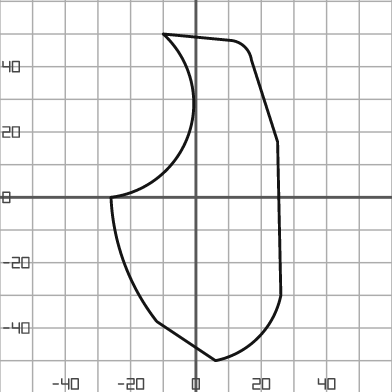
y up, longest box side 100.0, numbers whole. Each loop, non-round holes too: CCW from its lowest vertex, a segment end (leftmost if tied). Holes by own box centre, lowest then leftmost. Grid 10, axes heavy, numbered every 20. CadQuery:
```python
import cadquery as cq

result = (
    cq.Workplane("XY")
    .moveTo(6.0, -50.0)
    .threePointArc((19.0, -43.0), (26.0, -30.0))
    .lineTo(25.0, 17.0)
    .lineTo(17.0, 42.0)
    .threePointArc((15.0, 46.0), (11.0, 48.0))
    .lineTo(-10.0, 50.0)
    .threePointArc((-2.0, 20.0), (-26.0, 0.0))
    .threePointArc((-22.0, -20.0), (-12.0, -38.0))
    .close()
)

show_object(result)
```